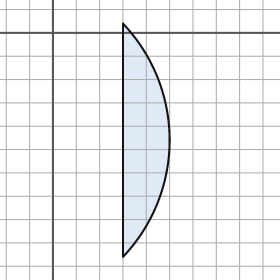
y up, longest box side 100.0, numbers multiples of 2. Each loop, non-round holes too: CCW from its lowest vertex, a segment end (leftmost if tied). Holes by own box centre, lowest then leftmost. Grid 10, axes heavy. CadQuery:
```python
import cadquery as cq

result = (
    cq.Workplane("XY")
    .moveTo(30.0, -96.0)
    .threePointArc((50.0, -46.0), (30.0, 4.0))
    .close()
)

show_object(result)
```